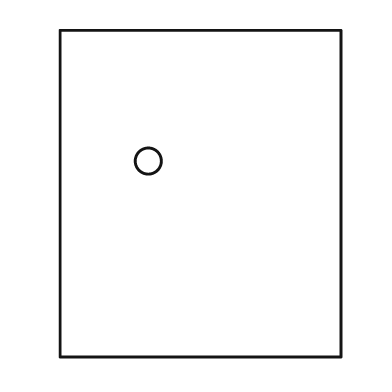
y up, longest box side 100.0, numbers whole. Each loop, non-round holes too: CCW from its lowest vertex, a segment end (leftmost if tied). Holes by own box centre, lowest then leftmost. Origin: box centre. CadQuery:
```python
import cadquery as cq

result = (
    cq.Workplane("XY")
    .moveTo(-43.0, -50.0)
    .lineTo(43.0, -50.0)
    .lineTo(43.0, 50.0)
    .lineTo(-43.0, 50.0)
    .close()
    .moveTo(-16.0, 10.0)
    .circle(4.0)
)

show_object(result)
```